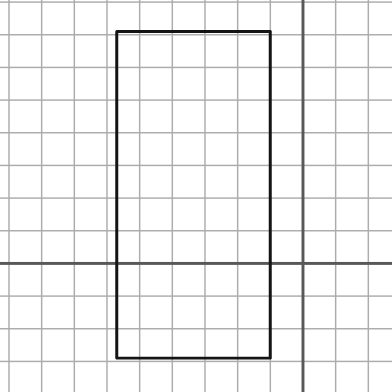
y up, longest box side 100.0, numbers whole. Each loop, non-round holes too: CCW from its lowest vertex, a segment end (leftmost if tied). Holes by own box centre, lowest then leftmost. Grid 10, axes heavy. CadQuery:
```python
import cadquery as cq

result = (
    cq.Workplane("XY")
    .moveTo(-57.0, -29.0)
    .lineTo(-10.0, -29.0)
    .lineTo(-10.0, 71.0)
    .lineTo(-57.0, 71.0)
    .close()
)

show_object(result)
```